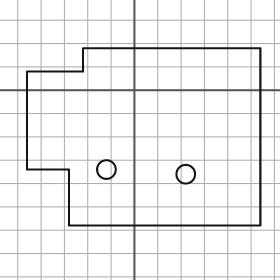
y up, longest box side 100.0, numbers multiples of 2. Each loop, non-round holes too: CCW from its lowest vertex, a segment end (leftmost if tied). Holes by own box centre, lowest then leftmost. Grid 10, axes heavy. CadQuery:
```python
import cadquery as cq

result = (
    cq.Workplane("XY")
    .moveTo(-28.0, -58.0)
    .lineTo(54.0, -58.0)
    .lineTo(54.0, 18.0)
    .lineTo(-22.0, 18.0)
    .lineTo(-22.0, 8.0)
    .lineTo(-46.0, 8.0)
    .lineTo(-46.0, -34.0)
    .lineTo(-28.0, -34.0)
    .close()
    .moveTo(22.0, -36.0)
    .circle(4.0)
    .moveTo(-12.0, -34.0)
    .circle(4.0)
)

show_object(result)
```